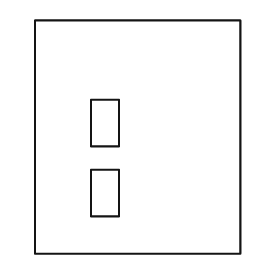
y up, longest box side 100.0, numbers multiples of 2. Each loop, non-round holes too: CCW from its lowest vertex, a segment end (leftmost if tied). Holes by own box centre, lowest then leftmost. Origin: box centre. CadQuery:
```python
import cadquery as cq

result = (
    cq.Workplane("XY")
    .moveTo(-44.0, -50.0)
    .lineTo(44.0, -50.0)
    .lineTo(44.0, 50.0)
    .lineTo(-44.0, 50.0)
    .close()
    .moveTo(-20.0, -34.0)
    .lineTo(-8.0, -34.0)
    .lineTo(-8.0, -14.0)
    .lineTo(-20.0, -14.0)
    .close()
    .moveTo(-20.0, -4.0)
    .lineTo(-8.0, -4.0)
    .lineTo(-8.0, 16.0)
    .lineTo(-20.0, 16.0)
    .close()
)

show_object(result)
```